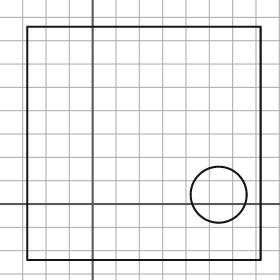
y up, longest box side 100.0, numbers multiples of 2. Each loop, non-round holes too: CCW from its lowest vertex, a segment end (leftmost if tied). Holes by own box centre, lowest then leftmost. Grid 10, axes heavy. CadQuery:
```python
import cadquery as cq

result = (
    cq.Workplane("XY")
    .moveTo(-28.0, -24.0)
    .lineTo(72.0, -24.0)
    .lineTo(72.0, 76.0)
    .lineTo(-28.0, 76.0)
    .close()
    .moveTo(54.0, 4.0)
    .circle(12.0)
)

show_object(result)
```